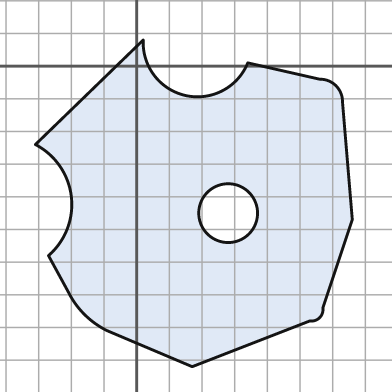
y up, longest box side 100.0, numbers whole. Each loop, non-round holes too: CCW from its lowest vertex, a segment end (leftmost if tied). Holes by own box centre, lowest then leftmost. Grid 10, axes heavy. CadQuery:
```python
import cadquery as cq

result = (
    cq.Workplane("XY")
    .moveTo(17.0, -92.0)
    .lineTo(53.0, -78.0)
    .threePointArc((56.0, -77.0), (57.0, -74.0))
    .lineTo(66.0, -47.0)
    .lineTo(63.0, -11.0)
    .threePointArc((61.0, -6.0), (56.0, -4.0))
    .lineTo(34.0, 1.0)
    .threePointArc((15.0, -9.0), (2.0, 8.0))
    .lineTo(-31.0, -24.0)
    .threePointArc((-20.0, -40.0), (-27.0, -58.0))
    .lineTo(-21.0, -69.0)
    .threePointArc((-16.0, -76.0), (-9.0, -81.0))
    .close()
    .moveTo(28.0, -45.0)
    .circle(9.0)
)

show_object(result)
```